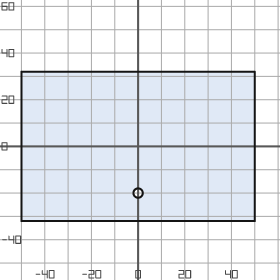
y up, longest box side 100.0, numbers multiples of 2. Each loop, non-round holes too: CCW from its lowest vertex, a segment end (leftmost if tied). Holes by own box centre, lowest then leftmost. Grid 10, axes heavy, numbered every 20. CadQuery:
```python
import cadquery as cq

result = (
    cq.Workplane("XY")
    .moveTo(-50.0, -32.0)
    .lineTo(50.0, -32.0)
    .lineTo(50.0, 32.0)
    .lineTo(-50.0, 32.0)
    .close()
    .moveTo(0.0, -20.0)
    .circle(2.0)
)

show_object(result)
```